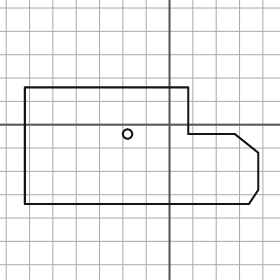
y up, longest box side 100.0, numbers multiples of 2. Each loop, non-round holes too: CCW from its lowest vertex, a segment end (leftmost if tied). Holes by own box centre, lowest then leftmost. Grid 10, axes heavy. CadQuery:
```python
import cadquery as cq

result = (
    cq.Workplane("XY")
    .moveTo(-62.0, -34.0)
    .lineTo(34.0, -34.0)
    .lineTo(38.0, -28.0)
    .lineTo(38.0, -12.0)
    .lineTo(28.0, -4.0)
    .lineTo(8.0, -4.0)
    .lineTo(8.0, 16.0)
    .lineTo(-62.0, 16.0)
    .close()
    .moveTo(-18.0, -4.0)
    .circle(2.0)
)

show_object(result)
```